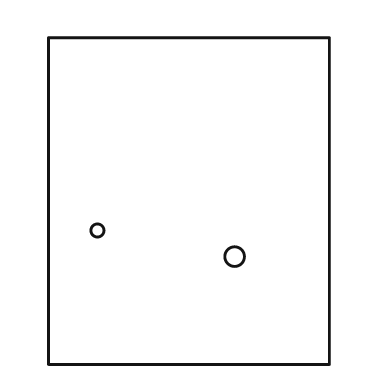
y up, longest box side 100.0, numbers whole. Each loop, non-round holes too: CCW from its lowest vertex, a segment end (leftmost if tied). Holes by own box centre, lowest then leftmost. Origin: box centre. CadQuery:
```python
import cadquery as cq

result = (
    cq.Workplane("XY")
    .moveTo(-43.0, -50.0)
    .lineTo(43.0, -50.0)
    .lineTo(43.0, 50.0)
    .lineTo(-43.0, 50.0)
    .close()
    .moveTo(14.0, -17.0)
    .circle(3.0)
    .moveTo(-28.0, -9.0)
    .circle(2.0)
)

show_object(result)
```